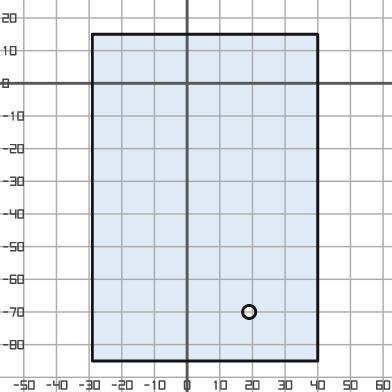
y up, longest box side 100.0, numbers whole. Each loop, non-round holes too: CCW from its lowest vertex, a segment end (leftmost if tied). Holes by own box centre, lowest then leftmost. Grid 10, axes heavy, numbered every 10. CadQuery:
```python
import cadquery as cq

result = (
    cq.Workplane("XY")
    .moveTo(-29.0, -85.0)
    .lineTo(40.0, -85.0)
    .lineTo(40.0, 15.0)
    .lineTo(-29.0, 15.0)
    .close()
    .moveTo(19.0, -70.0)
    .circle(2.0)
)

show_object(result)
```